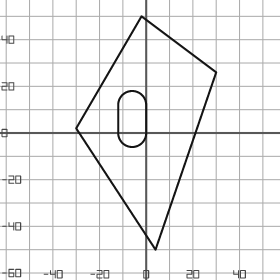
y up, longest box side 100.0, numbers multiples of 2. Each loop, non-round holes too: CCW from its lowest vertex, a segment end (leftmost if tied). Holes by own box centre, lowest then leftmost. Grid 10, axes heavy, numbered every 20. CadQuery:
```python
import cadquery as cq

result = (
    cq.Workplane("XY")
    .moveTo(4.0, -50.0)
    .lineTo(30.0, 26.0)
    .lineTo(-2.0, 50.0)
    .lineTo(-30.0, 2.0)
    .close()
    .moveTo(-12.0, 0.0)
    .threePointArc((-6.0, -6.0), (0.0, 0.0))
    .lineTo(0.0, 12.0)
    .threePointArc((-6.0, 18.0), (-12.0, 12.0))
    .close()
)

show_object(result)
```